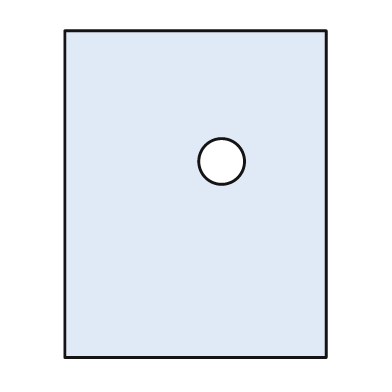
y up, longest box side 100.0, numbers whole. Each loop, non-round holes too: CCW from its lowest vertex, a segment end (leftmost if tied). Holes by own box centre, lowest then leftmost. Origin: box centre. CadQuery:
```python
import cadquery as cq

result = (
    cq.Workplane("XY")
    .moveTo(-40.0, -50.0)
    .lineTo(40.0, -50.0)
    .lineTo(40.0, 50.0)
    .lineTo(-40.0, 50.0)
    .close()
    .moveTo(8.0, 10.0)
    .circle(7.0)
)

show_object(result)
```